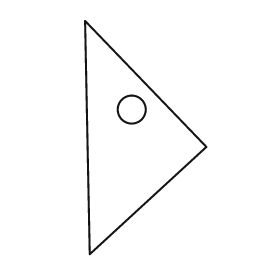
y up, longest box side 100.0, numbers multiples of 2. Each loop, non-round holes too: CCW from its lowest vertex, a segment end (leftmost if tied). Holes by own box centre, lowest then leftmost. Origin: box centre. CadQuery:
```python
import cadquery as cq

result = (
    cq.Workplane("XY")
    .moveTo(-24.0, -50.0)
    .lineTo(26.0, -4.0)
    .lineTo(-26.0, 50.0)
    .close()
    .moveTo(-6.0, 12.0)
    .circle(6.0)
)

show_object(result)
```